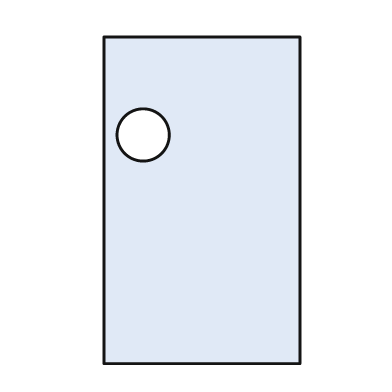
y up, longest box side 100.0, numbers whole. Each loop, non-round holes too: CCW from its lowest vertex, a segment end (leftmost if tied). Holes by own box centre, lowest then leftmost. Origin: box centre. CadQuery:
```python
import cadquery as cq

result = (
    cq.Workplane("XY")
    .moveTo(-30.0, -50.0)
    .lineTo(30.0, -50.0)
    .lineTo(30.0, 50.0)
    .lineTo(-30.0, 50.0)
    .close()
    .moveTo(-18.0, 20.0)
    .circle(8.0)
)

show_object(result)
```